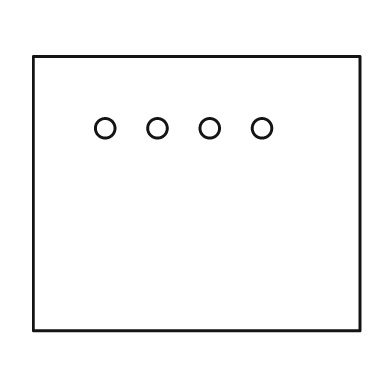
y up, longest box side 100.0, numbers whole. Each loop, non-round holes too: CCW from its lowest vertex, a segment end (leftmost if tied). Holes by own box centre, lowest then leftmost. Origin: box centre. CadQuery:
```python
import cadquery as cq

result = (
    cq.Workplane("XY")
    .moveTo(-50.0, -42.0)
    .lineTo(50.0, -42.0)
    .lineTo(50.0, 42.0)
    .lineTo(-50.0, 42.0)
    .close()
    .moveTo(-28.0, 20.0)
    .circle(3.0)
    .moveTo(-12.0, 20.0)
    .circle(3.0)
    .moveTo(4.0, 20.0)
    .circle(3.0)
    .moveTo(20.0, 20.0)
    .circle(3.0)
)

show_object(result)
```